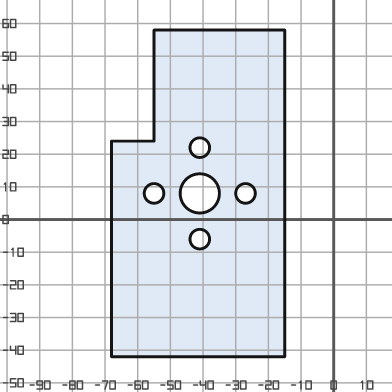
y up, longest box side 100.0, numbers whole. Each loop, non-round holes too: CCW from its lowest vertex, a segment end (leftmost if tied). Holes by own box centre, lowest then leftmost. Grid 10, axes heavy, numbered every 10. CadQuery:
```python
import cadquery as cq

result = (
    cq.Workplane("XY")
    .moveTo(-68.0, -42.0)
    .lineTo(-15.0, -42.0)
    .lineTo(-15.0, 58.0)
    .lineTo(-55.0, 58.0)
    .lineTo(-55.0, 24.0)
    .lineTo(-68.0, 24.0)
    .close()
    .moveTo(-41.0, -6.0)
    .circle(3.0)
    .moveTo(-55.0, 8.0)
    .circle(3.0)
    .moveTo(-41.0, 8.0)
    .circle(6.0)
    .moveTo(-27.0, 8.0)
    .circle(3.0)
    .moveTo(-41.0, 22.0)
    .circle(3.0)
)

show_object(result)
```